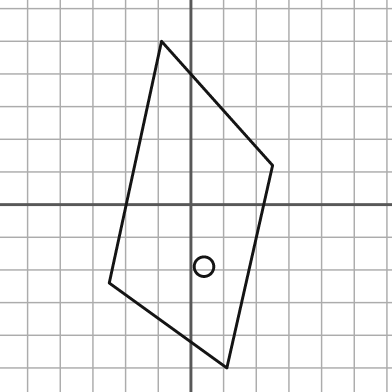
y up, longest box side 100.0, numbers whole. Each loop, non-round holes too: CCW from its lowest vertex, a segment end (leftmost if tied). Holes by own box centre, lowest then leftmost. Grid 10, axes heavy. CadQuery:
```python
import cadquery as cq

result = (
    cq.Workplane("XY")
    .moveTo(11.0, -50.0)
    .lineTo(25.0, 12.0)
    .lineTo(-9.0, 50.0)
    .lineTo(-25.0, -24.0)
    .close()
    .moveTo(4.0, -19.0)
    .circle(3.0)
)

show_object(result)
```